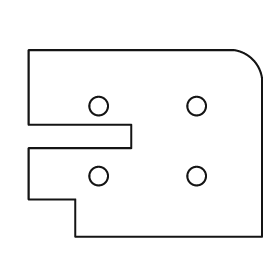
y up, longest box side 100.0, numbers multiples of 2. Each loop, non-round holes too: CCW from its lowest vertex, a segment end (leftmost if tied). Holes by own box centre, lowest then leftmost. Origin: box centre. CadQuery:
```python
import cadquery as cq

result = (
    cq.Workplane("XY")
    .moveTo(-30.0, -40.0)
    .lineTo(50.0, -40.0)
    .lineTo(50.0, 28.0)
    .threePointArc((46.0, 36.0), (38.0, 40.0))
    .lineTo(-50.0, 40.0)
    .lineTo(-50.0, 8.0)
    .lineTo(-6.0, 8.0)
    .lineTo(-6.0, -2.0)
    .lineTo(-50.0, -2.0)
    .lineTo(-50.0, -24.0)
    .lineTo(-30.0, -24.0)
    .close()
    .moveTo(-20.0, -14.0)
    .circle(4.0)
    .moveTo(22.0, -14.0)
    .circle(4.0)
    .moveTo(-20.0, 16.0)
    .circle(4.0)
    .moveTo(22.0, 16.0)
    .circle(4.0)
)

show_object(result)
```